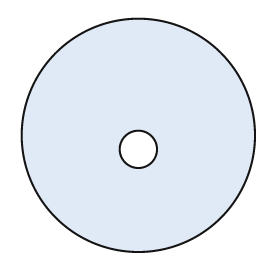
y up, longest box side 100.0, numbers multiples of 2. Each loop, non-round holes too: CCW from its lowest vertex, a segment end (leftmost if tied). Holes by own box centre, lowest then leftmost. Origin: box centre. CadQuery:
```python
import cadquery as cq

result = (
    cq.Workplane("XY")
    .moveTo(0.0, 0.0)
    .circle(50.0)
    .moveTo(0.0, -6.0)
    .circle(8.0)
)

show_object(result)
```